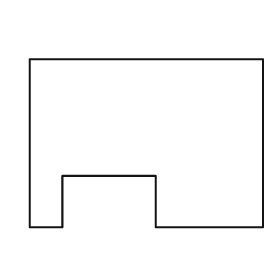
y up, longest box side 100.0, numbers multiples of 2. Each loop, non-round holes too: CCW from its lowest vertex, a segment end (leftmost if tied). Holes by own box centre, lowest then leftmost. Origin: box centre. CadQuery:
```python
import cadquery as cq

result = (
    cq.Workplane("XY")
    .moveTo(-50.0, -36.0)
    .lineTo(-36.0, -36.0)
    .lineTo(-36.0, -14.0)
    .lineTo(4.0, -14.0)
    .lineTo(4.0, -36.0)
    .lineTo(50.0, -36.0)
    .lineTo(50.0, 36.0)
    .lineTo(-50.0, 36.0)
    .close()
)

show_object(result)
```